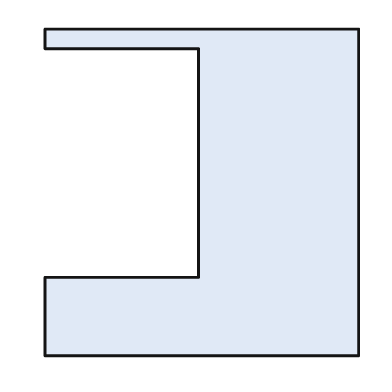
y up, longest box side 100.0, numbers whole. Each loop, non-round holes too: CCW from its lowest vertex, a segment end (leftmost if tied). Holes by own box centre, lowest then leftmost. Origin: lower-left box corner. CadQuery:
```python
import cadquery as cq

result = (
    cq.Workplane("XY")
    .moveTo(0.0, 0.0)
    .lineTo(96.0, 0.0)
    .lineTo(96.0, 100.0)
    .lineTo(0.0, 100.0)
    .lineTo(0.0, 94.0)
    .lineTo(47.0, 94.0)
    .lineTo(47.0, 24.0)
    .lineTo(0.0, 24.0)
    .close()
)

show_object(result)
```